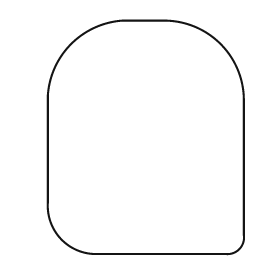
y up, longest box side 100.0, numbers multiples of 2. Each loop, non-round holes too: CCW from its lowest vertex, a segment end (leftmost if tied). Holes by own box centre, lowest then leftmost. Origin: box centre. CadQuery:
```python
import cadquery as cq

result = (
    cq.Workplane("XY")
    .moveTo(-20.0, -50.0)
    .lineTo(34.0, -50.0)
    .threePointArc((40.0, -48.0), (42.0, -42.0))
    .lineTo(42.0, 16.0)
    .threePointArc((32.0, 40.0), (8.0, 50.0))
    .lineTo(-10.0, 50.0)
    .threePointArc((-32.0, 40.0), (-42.0, 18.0))
    .lineTo(-42.0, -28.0)
    .threePointArc((-36.0, -44.0), (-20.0, -50.0))
    .close()
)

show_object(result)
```